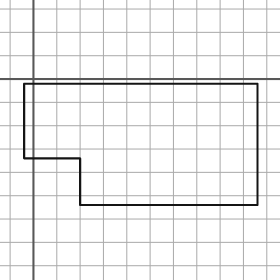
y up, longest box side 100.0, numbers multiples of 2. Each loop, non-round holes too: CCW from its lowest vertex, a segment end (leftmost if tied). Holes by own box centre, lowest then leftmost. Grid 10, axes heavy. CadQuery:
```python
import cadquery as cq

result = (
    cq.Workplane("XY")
    .moveTo(20.0, -54.0)
    .lineTo(96.0, -54.0)
    .lineTo(96.0, -2.0)
    .lineTo(-4.0, -2.0)
    .lineTo(-4.0, -34.0)
    .lineTo(20.0, -34.0)
    .close()
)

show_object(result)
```